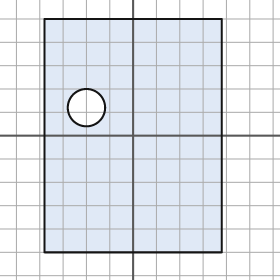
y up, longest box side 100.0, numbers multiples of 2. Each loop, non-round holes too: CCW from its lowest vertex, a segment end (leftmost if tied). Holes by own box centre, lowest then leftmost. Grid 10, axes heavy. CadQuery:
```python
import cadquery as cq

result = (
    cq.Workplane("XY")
    .moveTo(-38.0, -50.0)
    .lineTo(38.0, -50.0)
    .lineTo(38.0, 50.0)
    .lineTo(-38.0, 50.0)
    .close()
    .moveTo(-20.0, 12.0)
    .circle(8.0)
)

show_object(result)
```